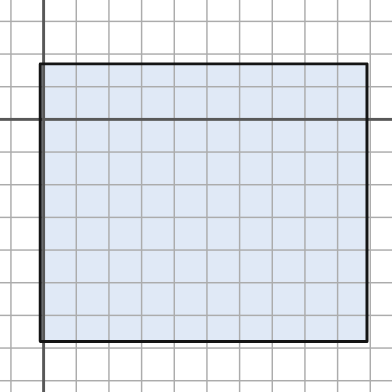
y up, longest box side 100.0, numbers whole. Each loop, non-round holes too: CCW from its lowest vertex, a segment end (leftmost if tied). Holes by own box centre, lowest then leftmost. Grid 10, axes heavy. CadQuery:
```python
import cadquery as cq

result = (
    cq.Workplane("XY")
    .moveTo(-1.0, -68.0)
    .lineTo(99.0, -68.0)
    .lineTo(99.0, 17.0)
    .lineTo(-1.0, 17.0)
    .close()
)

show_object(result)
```